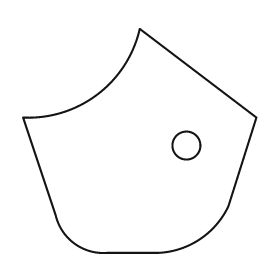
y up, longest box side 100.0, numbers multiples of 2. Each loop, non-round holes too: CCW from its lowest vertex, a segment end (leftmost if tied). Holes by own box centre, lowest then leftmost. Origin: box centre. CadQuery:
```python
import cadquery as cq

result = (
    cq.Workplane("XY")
    .moveTo(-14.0, -48.0)
    .lineTo(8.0, -48.0)
    .threePointArc((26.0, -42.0), (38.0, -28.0))
    .lineTo(50.0, 10.0)
    .lineTo(0.0, 48.0)
    .threePointArc((-18.0, 20.0), (-50.0, 10.0))
    .lineTo(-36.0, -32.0)
    .threePointArc((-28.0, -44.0), (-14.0, -48.0))
    .close()
    .moveTo(20.0, -2.0)
    .circle(6.0)
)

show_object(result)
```